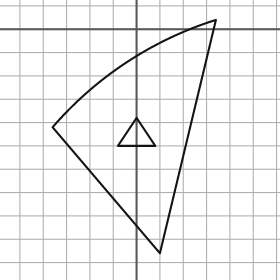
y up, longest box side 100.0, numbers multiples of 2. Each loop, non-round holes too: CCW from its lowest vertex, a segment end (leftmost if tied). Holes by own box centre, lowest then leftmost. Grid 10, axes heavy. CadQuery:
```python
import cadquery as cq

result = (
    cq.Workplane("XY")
    .moveTo(10.0, -96.0)
    .lineTo(34.0, 4.0)
    .threePointArc((-4.0, -14.0), (-36.0, -42.0))
    .close()
    .moveTo(-8.0, -50.0)
    .lineTo(8.0, -50.0)
    .lineTo(0.0, -38.0)
    .close()
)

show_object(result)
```